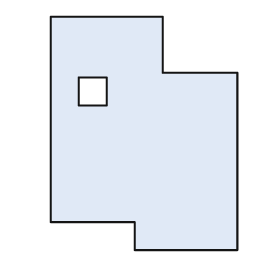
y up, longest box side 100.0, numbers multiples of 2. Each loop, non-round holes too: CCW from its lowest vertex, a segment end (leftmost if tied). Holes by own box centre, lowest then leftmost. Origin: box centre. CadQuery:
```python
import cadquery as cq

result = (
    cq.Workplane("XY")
    .moveTo(-4.0, -50.0)
    .lineTo(40.0, -50.0)
    .lineTo(40.0, 26.0)
    .lineTo(8.0, 26.0)
    .lineTo(8.0, 50.0)
    .lineTo(-40.0, 50.0)
    .lineTo(-40.0, -38.0)
    .lineTo(-4.0, -38.0)
    .close()
    .moveTo(-28.0, 12.0)
    .lineTo(-16.0, 12.0)
    .lineTo(-16.0, 24.0)
    .lineTo(-28.0, 24.0)
    .close()
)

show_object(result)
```